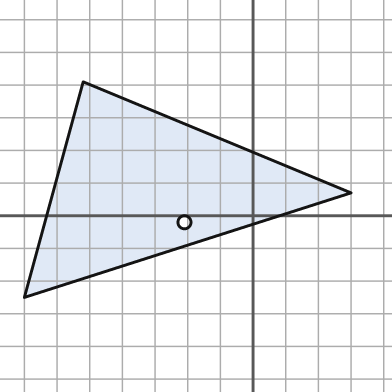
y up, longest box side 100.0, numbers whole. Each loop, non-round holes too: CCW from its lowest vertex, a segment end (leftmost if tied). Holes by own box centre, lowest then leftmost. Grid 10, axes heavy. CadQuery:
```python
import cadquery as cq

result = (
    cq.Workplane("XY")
    .moveTo(-70.0, -25.0)
    .lineTo(30.0, 7.0)
    .lineTo(-52.0, 41.0)
    .close()
    .moveTo(-21.0, -2.0)
    .circle(2.0)
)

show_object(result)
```